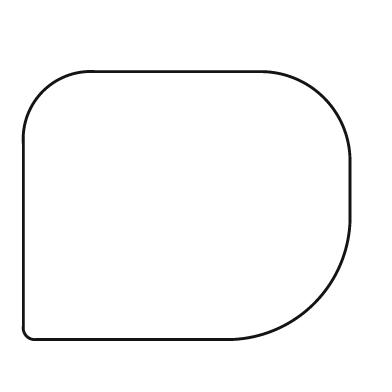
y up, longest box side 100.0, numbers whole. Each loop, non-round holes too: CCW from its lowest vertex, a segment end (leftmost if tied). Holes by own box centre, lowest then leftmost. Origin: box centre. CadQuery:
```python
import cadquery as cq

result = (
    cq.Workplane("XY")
    .moveTo(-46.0, -41.0)
    .lineTo(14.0, -41.0)
    .threePointArc((39.0, -30.0), (50.0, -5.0))
    .lineTo(50.0, 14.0)
    .threePointArc((42.0, 33.0), (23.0, 41.0))
    .lineTo(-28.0, 41.0)
    .threePointArc((-44.0, 35.0), (-50.0, 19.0))
    .lineTo(-50.0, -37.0)
    .threePointArc((-49.0, -40.0), (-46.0, -41.0))
    .close()
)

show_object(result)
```